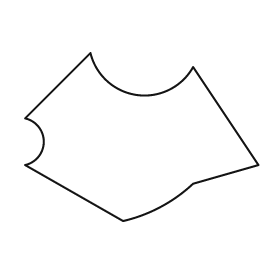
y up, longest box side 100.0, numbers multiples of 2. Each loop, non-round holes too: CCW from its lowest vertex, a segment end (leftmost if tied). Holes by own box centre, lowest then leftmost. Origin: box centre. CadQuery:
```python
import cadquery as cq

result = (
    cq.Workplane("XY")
    .moveTo(-8.0, -36.0)
    .threePointArc((8.0, -30.0), (22.0, -20.0))
    .lineTo(50.0, -12.0)
    .lineTo(22.0, 30.0)
    .threePointArc((-2.0, 18.0), (-22.0, 36.0))
    .lineTo(-50.0, 8.0)
    .threePointArc((-42.0, -2.0), (-50.0, -12.0))
    .close()
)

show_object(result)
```